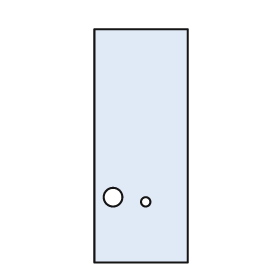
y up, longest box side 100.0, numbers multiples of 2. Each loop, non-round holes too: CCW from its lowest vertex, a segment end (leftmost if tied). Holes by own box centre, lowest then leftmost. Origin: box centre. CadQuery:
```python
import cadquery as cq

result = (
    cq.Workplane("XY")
    .moveTo(-20.0, -50.0)
    .lineTo(20.0, -50.0)
    .lineTo(20.0, 50.0)
    .lineTo(-20.0, 50.0)
    .close()
    .moveTo(2.0, -24.0)
    .circle(2.0)
    .moveTo(-12.0, -22.0)
    .circle(4.0)
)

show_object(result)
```